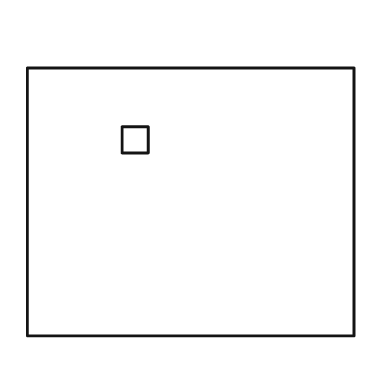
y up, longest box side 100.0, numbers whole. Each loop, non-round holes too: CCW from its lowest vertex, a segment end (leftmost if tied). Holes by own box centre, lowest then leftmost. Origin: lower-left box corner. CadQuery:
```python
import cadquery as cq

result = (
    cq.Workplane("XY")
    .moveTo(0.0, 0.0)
    .lineTo(100.0, 0.0)
    .lineTo(100.0, 82.0)
    .lineTo(0.0, 82.0)
    .close()
    .moveTo(29.0, 56.0)
    .lineTo(37.0, 56.0)
    .lineTo(37.0, 64.0)
    .lineTo(29.0, 64.0)
    .close()
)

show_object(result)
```